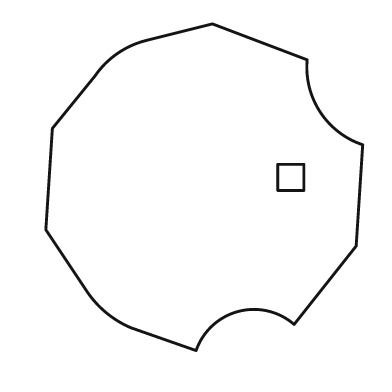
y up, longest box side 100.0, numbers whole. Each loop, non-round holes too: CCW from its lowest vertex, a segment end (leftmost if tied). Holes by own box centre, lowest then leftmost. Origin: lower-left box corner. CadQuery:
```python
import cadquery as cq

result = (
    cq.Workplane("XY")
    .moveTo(46.0, 0.0)
    .threePointArc((59.0, 12.0), (76.0, 8.0))
    .lineTo(95.0, 32.0)
    .lineTo(97.0, 63.0)
    .threePointArc((84.0, 73.0), (80.0, 89.0))
    .lineTo(51.0, 100.0)
    .lineTo(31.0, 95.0)
    .threePointArc((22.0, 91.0), (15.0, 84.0))
    .lineTo(2.0, 68.0)
    .lineTo(0.0, 37.0)
    .lineTo(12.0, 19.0)
    .threePointArc((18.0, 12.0), (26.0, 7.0))
    .close()
    .moveTo(71.0, 49.0)
    .lineTo(79.0, 49.0)
    .lineTo(79.0, 57.0)
    .lineTo(71.0, 57.0)
    .close()
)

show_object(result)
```